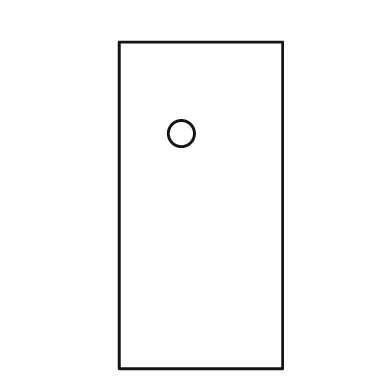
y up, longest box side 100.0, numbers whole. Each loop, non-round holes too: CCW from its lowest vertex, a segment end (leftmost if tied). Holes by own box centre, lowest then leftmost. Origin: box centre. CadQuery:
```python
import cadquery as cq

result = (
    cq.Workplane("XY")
    .moveTo(-25.0, -50.0)
    .lineTo(25.0, -50.0)
    .lineTo(25.0, 50.0)
    .lineTo(-25.0, 50.0)
    .close()
    .moveTo(-6.0, 22.0)
    .circle(4.0)
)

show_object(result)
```